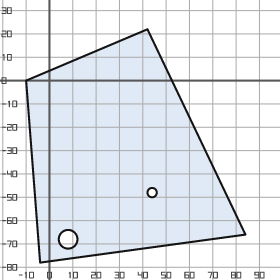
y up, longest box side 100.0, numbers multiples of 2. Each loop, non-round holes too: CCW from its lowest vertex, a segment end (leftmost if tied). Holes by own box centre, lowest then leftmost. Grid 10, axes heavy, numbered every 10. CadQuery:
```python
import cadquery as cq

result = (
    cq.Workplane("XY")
    .moveTo(-4.0, -78.0)
    .lineTo(84.0, -66.0)
    .lineTo(42.0, 22.0)
    .lineTo(-10.0, 0.0)
    .close()
    .moveTo(8.0, -68.0)
    .circle(4.0)
    .moveTo(44.0, -48.0)
    .circle(2.0)
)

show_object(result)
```